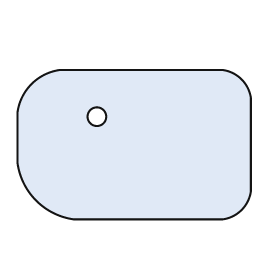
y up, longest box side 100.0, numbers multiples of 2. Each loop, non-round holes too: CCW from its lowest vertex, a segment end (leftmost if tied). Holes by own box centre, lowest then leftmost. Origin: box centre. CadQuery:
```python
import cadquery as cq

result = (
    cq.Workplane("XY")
    .moveTo(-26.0, -32.0)
    .lineTo(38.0, -32.0)
    .threePointArc((46.0, -28.0), (50.0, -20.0))
    .lineTo(50.0, 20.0)
    .threePointArc((46.0, 28.0), (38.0, 32.0))
    .lineTo(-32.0, 32.0)
    .threePointArc((-44.0, 26.0), (-50.0, 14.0))
    .lineTo(-50.0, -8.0)
    .threePointArc((-42.0, -24.0), (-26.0, -32.0))
    .close()
    .moveTo(-16.0, 12.0)
    .circle(4.0)
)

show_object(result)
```